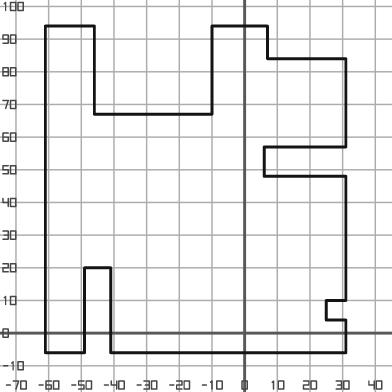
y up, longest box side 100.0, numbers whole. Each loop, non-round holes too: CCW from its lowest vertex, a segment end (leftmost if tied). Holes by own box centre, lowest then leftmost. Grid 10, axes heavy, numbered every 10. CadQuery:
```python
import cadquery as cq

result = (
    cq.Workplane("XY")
    .moveTo(-61.0, -6.0)
    .lineTo(-49.0, -6.0)
    .lineTo(-49.0, 20.0)
    .lineTo(-41.0, 20.0)
    .lineTo(-41.0, -6.0)
    .lineTo(31.0, -6.0)
    .lineTo(31.0, 4.0)
    .lineTo(25.0, 4.0)
    .lineTo(25.0, 10.0)
    .lineTo(31.0, 10.0)
    .lineTo(31.0, 48.0)
    .lineTo(6.0, 48.0)
    .lineTo(6.0, 57.0)
    .lineTo(31.0, 57.0)
    .lineTo(31.0, 84.0)
    .lineTo(7.0, 84.0)
    .lineTo(7.0, 94.0)
    .lineTo(-10.0, 94.0)
    .lineTo(-10.0, 67.0)
    .lineTo(-46.0, 67.0)
    .lineTo(-46.0, 94.0)
    .lineTo(-61.0, 94.0)
    .close()
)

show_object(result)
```